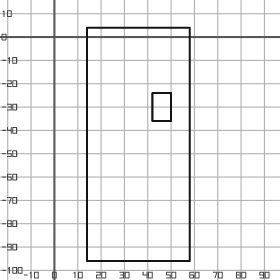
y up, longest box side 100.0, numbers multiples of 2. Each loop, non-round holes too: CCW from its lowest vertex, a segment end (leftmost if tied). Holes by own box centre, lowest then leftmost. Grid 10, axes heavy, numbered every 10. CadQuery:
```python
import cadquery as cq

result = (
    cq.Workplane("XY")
    .moveTo(14.0, -96.0)
    .lineTo(58.0, -96.0)
    .lineTo(58.0, 4.0)
    .lineTo(14.0, 4.0)
    .close()
    .moveTo(42.0, -36.0)
    .lineTo(50.0, -36.0)
    .lineTo(50.0, -24.0)
    .lineTo(42.0, -24.0)
    .close()
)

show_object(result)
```